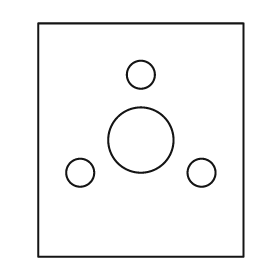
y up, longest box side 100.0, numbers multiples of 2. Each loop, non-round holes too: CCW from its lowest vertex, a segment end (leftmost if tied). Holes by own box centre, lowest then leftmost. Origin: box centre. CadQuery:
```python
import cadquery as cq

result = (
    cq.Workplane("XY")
    .moveTo(-44.0, -50.0)
    .lineTo(44.0, -50.0)
    .lineTo(44.0, 50.0)
    .lineTo(-44.0, 50.0)
    .close()
    .moveTo(-26.0, -14.0)
    .circle(6.0)
    .moveTo(26.0, -14.0)
    .circle(6.0)
    .moveTo(0.0, 0.0)
    .circle(14.0)
    .moveTo(0.0, 28.0)
    .circle(6.0)
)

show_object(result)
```